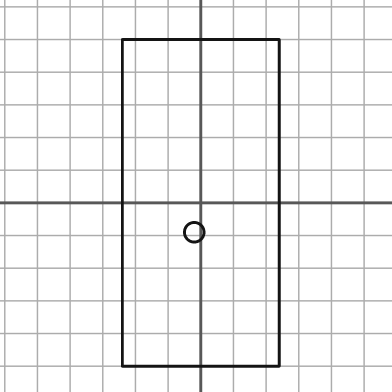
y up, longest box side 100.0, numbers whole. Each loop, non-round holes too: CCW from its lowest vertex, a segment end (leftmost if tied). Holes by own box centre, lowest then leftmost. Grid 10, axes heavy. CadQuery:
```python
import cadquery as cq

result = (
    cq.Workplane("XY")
    .moveTo(-24.0, -50.0)
    .lineTo(24.0, -50.0)
    .lineTo(24.0, 50.0)
    .lineTo(-24.0, 50.0)
    .close()
    .moveTo(-2.0, -9.0)
    .circle(3.0)
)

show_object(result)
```